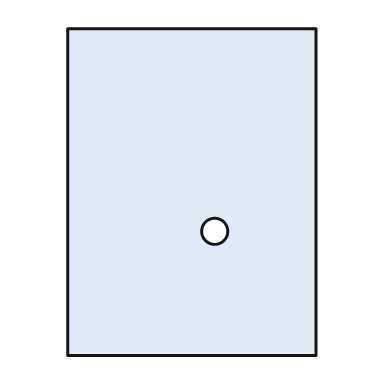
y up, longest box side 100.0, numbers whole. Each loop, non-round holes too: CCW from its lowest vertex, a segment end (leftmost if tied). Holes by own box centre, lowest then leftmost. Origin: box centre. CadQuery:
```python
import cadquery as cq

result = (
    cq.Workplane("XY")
    .moveTo(-38.0, -50.0)
    .lineTo(38.0, -50.0)
    .lineTo(38.0, 50.0)
    .lineTo(-38.0, 50.0)
    .close()
    .moveTo(7.0, -12.0)
    .circle(4.0)
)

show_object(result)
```